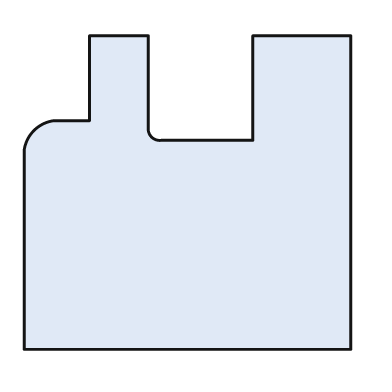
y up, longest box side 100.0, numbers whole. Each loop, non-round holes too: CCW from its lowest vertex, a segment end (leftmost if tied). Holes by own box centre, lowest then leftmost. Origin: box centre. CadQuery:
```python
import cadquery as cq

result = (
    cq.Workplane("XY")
    .moveTo(-50.0, -48.0)
    .lineTo(50.0, -48.0)
    .lineTo(50.0, 48.0)
    .lineTo(20.0, 48.0)
    .lineTo(20.0, 16.0)
    .lineTo(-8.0, 16.0)
    .threePointArc((-11.0, 17.0), (-12.0, 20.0))
    .lineTo(-12.0, 48.0)
    .lineTo(-30.0, 48.0)
    .lineTo(-30.0, 22.0)
    .lineTo(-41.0, 22.0)
    .threePointArc((-47.0, 19.0), (-50.0, 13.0))
    .close()
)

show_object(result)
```